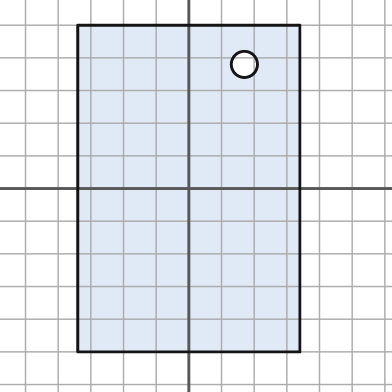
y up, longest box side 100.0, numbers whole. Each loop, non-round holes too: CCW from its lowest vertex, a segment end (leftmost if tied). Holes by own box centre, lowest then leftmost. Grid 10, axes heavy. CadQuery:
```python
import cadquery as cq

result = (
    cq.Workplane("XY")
    .moveTo(-34.0, -50.0)
    .lineTo(34.0, -50.0)
    .lineTo(34.0, 50.0)
    .lineTo(-34.0, 50.0)
    .close()
    .moveTo(17.0, 38.0)
    .circle(4.0)
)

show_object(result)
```